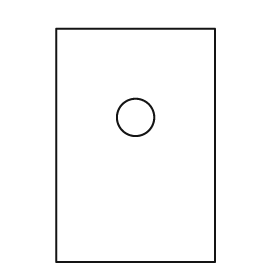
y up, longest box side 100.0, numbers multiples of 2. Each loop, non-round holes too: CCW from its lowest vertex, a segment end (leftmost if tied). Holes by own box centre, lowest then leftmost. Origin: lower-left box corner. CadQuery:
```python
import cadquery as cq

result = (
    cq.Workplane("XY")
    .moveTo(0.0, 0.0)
    .lineTo(68.0, 0.0)
    .lineTo(68.0, 100.0)
    .lineTo(0.0, 100.0)
    .close()
    .moveTo(34.0, 62.0)
    .circle(8.0)
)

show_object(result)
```